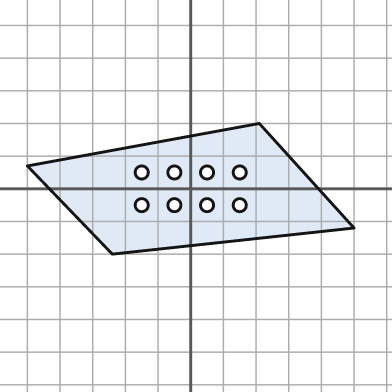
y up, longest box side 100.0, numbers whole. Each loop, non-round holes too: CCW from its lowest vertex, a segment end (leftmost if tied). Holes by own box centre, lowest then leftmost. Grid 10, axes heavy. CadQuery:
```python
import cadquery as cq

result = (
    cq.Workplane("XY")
    .moveTo(-24.0, -20.0)
    .lineTo(50.0, -12.0)
    .lineTo(21.0, 20.0)
    .lineTo(-50.0, 7.0)
    .close()
    .moveTo(-15.0, -5.0)
    .circle(2.0)
    .moveTo(-5.0, -5.0)
    .circle(2.0)
    .moveTo(5.0, -5.0)
    .circle(2.0)
    .moveTo(15.0, -5.0)
    .circle(2.0)
    .moveTo(-15.0, 5.0)
    .circle(2.0)
    .moveTo(-5.0, 5.0)
    .circle(2.0)
    .moveTo(5.0, 5.0)
    .circle(2.0)
    .moveTo(15.0, 5.0)
    .circle(2.0)
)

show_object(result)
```